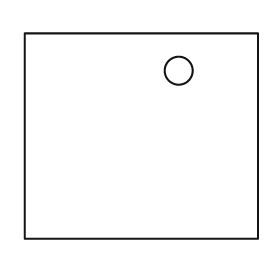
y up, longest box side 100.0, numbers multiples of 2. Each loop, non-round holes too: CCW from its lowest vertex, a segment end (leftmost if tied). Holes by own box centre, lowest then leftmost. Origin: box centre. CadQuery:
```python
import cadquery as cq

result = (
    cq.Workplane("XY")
    .moveTo(-50.0, -44.0)
    .lineTo(50.0, -44.0)
    .lineTo(50.0, 44.0)
    .lineTo(-50.0, 44.0)
    .close()
    .moveTo(16.0, 28.0)
    .circle(6.0)
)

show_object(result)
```